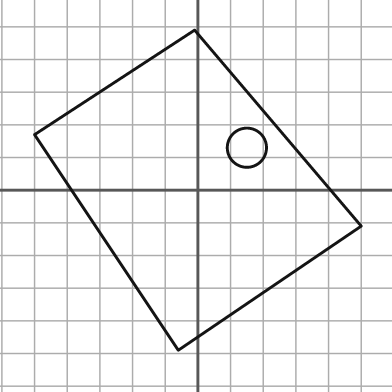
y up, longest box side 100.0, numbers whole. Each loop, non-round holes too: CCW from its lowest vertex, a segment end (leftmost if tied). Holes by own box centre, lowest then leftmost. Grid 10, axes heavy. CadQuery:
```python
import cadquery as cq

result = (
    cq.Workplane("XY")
    .moveTo(-6.0, -49.0)
    .lineTo(50.0, -11.0)
    .lineTo(-1.0, 49.0)
    .lineTo(-50.0, 17.0)
    .close()
    .moveTo(15.0, 13.0)
    .circle(6.0)
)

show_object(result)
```